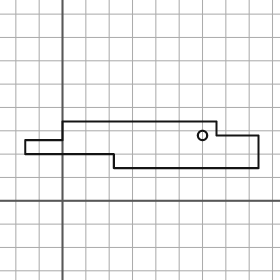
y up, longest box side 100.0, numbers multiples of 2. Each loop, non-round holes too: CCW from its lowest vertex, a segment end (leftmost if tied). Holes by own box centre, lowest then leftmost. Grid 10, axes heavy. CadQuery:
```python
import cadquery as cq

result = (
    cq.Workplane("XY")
    .moveTo(22.0, 14.0)
    .lineTo(84.0, 14.0)
    .lineTo(84.0, 28.0)
    .lineTo(66.0, 28.0)
    .lineTo(66.0, 34.0)
    .lineTo(0.0, 34.0)
    .lineTo(0.0, 26.0)
    .lineTo(-16.0, 26.0)
    .lineTo(-16.0, 20.0)
    .lineTo(22.0, 20.0)
    .close()
    .moveTo(60.0, 28.0)
    .circle(2.0)
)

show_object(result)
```